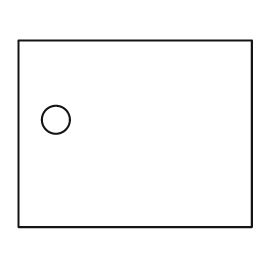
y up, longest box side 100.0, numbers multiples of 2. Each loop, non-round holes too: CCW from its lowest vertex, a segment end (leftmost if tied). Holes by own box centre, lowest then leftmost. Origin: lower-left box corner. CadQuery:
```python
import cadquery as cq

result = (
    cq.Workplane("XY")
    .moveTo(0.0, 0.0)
    .lineTo(100.0, 0.0)
    .lineTo(100.0, 80.0)
    .lineTo(0.0, 80.0)
    .close()
    .moveTo(16.0, 46.0)
    .circle(6.0)
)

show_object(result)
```